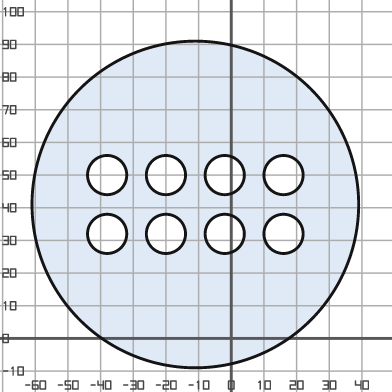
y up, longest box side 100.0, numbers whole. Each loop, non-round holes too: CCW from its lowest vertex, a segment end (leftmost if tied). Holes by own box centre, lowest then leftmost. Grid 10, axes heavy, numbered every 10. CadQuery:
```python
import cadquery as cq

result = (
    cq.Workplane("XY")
    .moveTo(-11.0, 41.0)
    .circle(50.0)
    .moveTo(-38.0, 32.0)
    .circle(6.0)
    .moveTo(-20.0, 32.0)
    .circle(6.0)
    .moveTo(-2.0, 32.0)
    .circle(6.0)
    .moveTo(16.0, 32.0)
    .circle(6.0)
    .moveTo(-38.0, 50.0)
    .circle(6.0)
    .moveTo(-20.0, 50.0)
    .circle(6.0)
    .moveTo(-2.0, 50.0)
    .circle(6.0)
    .moveTo(16.0, 50.0)
    .circle(6.0)
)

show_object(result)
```